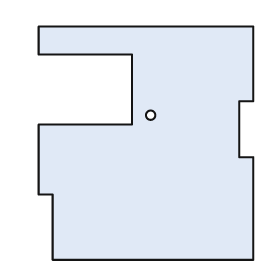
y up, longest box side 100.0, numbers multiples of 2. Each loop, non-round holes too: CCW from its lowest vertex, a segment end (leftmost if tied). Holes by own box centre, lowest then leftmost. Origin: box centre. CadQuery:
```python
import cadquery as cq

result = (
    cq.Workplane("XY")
    .moveTo(-40.0, -50.0)
    .lineTo(46.0, -50.0)
    .lineTo(46.0, -6.0)
    .lineTo(40.0, -6.0)
    .lineTo(40.0, 18.0)
    .lineTo(46.0, 18.0)
    .lineTo(46.0, 50.0)
    .lineTo(-46.0, 50.0)
    .lineTo(-46.0, 38.0)
    .lineTo(-6.0, 38.0)
    .lineTo(-6.0, 8.0)
    .lineTo(-46.0, 8.0)
    .lineTo(-46.0, -22.0)
    .lineTo(-40.0, -22.0)
    .close()
    .moveTo(2.0, 12.0)
    .circle(2.0)
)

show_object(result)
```